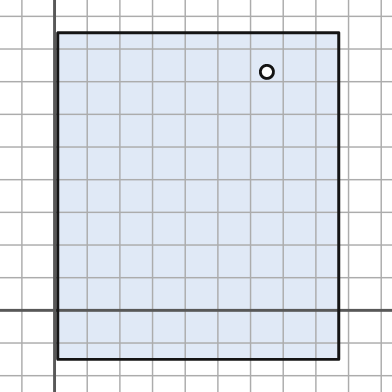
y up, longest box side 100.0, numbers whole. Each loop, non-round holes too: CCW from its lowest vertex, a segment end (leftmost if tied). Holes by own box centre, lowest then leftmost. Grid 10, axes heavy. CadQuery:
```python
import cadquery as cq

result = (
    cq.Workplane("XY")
    .moveTo(1.0, -15.0)
    .lineTo(87.0, -15.0)
    .lineTo(87.0, 85.0)
    .lineTo(1.0, 85.0)
    .close()
    .moveTo(65.0, 73.0)
    .circle(2.0)
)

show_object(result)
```